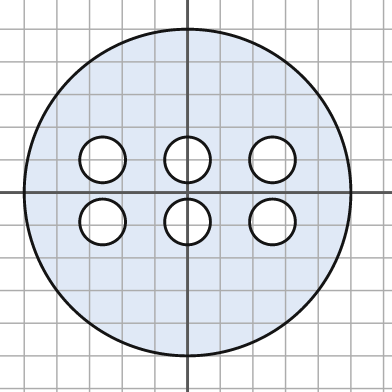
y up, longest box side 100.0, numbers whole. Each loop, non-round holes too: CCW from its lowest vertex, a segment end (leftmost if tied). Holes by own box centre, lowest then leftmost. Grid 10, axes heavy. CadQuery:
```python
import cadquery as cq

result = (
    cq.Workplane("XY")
    .moveTo(0.0, 0.0)
    .circle(50.0)
    .moveTo(-26.0, -9.0)
    .circle(7.0)
    .moveTo(0.0, -9.0)
    .circle(7.0)
    .moveTo(26.0, -9.0)
    .circle(7.0)
    .moveTo(-26.0, 10.0)
    .circle(7.0)
    .moveTo(0.0, 10.0)
    .circle(7.0)
    .moveTo(26.0, 10.0)
    .circle(7.0)
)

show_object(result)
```